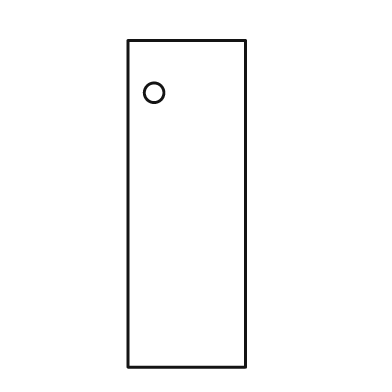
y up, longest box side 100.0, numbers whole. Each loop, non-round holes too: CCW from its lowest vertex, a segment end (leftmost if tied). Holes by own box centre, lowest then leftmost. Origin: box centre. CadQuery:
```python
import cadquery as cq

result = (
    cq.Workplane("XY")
    .moveTo(-18.0, -50.0)
    .lineTo(18.0, -50.0)
    .lineTo(18.0, 50.0)
    .lineTo(-18.0, 50.0)
    .close()
    .moveTo(-10.0, 34.0)
    .circle(3.0)
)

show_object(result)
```